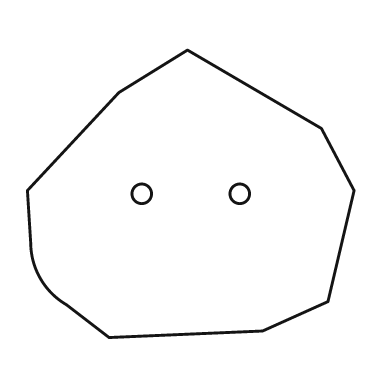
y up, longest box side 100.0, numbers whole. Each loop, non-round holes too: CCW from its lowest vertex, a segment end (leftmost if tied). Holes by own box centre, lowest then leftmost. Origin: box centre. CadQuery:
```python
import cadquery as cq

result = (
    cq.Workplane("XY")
    .moveTo(-25.0, -44.0)
    .lineTo(22.0, -42.0)
    .lineTo(42.0, -33.0)
    .lineTo(50.0, 1.0)
    .lineTo(40.0, 20.0)
    .lineTo(-1.0, 44.0)
    .lineTo(-22.0, 31.0)
    .lineTo(-50.0, 1.0)
    .lineTo(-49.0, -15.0)
    .threePointArc((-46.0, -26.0), (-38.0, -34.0))
    .close()
    .moveTo(-15.0, 0.0)
    .circle(3.0)
    .moveTo(15.0, 0.0)
    .circle(3.0)
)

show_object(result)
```